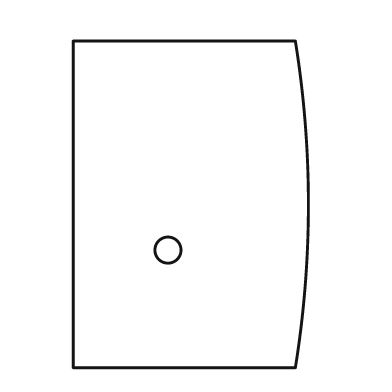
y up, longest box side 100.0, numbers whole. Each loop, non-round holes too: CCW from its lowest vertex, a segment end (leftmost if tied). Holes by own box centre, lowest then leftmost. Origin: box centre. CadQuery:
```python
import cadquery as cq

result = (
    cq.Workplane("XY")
    .moveTo(-36.0, -50.0)
    .lineTo(32.0, -50.0)
    .threePointArc((36.0, 0.0), (32.0, 50.0))
    .lineTo(-36.0, 50.0)
    .close()
    .moveTo(-7.0, -14.0)
    .circle(4.0)
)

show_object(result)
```